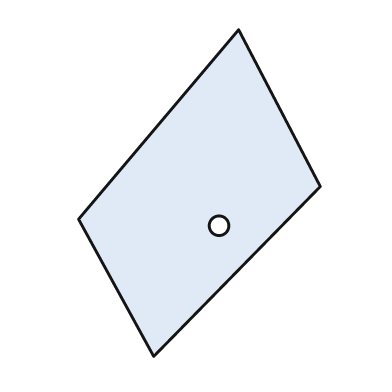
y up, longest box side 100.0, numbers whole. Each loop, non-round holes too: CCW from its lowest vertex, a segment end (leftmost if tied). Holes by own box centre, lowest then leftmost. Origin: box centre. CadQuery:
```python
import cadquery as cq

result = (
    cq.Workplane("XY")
    .moveTo(-14.0, -50.0)
    .lineTo(37.0, 2.0)
    .lineTo(12.0, 50.0)
    .lineTo(-37.0, -8.0)
    .close()
    .moveTo(6.0, -10.0)
    .circle(3.0)
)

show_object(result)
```